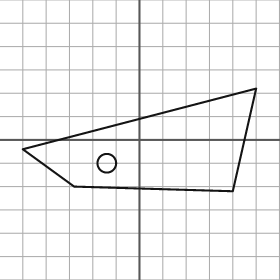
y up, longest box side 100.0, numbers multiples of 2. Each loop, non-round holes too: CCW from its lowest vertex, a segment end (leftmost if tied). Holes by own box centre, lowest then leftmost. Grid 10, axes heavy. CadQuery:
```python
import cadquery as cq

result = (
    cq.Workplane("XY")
    .moveTo(40.0, -22.0)
    .lineTo(50.0, 22.0)
    .lineTo(-50.0, -4.0)
    .lineTo(-28.0, -20.0)
    .close()
    .moveTo(-14.0, -10.0)
    .circle(4.0)
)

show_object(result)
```